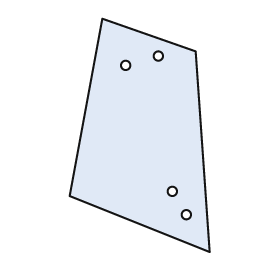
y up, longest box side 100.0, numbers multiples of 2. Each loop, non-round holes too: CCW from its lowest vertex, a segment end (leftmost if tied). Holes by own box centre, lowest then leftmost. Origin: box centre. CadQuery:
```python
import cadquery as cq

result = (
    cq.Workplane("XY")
    .moveTo(30.0, -50.0)
    .lineTo(24.0, 36.0)
    .lineTo(-16.0, 50.0)
    .lineTo(-30.0, -26.0)
    .close()
    .moveTo(20.0, -34.0)
    .circle(2.0)
    .moveTo(14.0, -24.0)
    .circle(2.0)
    .moveTo(-6.0, 30.0)
    .circle(2.0)
    .moveTo(8.0, 34.0)
    .circle(2.0)
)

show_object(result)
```